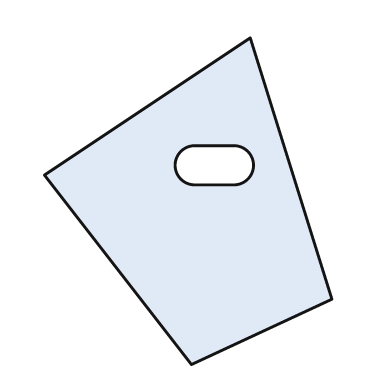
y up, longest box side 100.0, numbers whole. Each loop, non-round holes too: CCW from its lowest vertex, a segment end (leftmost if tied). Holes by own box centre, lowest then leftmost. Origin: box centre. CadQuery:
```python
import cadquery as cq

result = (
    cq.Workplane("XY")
    .moveTo(1.0, -50.0)
    .lineTo(44.0, -30.0)
    .lineTo(19.0, 50.0)
    .lineTo(-44.0, 8.0)
    .close()
    .moveTo(2.0, 5.0)
    .lineTo(14.0, 5.0)
    .threePointArc((20.0, 11.0), (14.0, 17.0))
    .lineTo(2.0, 17.0)
    .threePointArc((-4.0, 11.0), (2.0, 5.0))
    .close()
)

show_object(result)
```